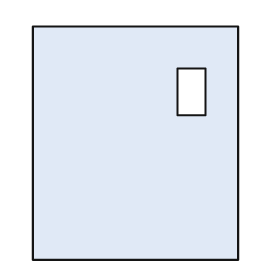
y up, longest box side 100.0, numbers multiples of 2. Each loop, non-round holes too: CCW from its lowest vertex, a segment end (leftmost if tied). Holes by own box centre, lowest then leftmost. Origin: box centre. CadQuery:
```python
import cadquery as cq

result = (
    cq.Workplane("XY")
    .moveTo(-44.0, -50.0)
    .lineTo(44.0, -50.0)
    .lineTo(44.0, 50.0)
    .lineTo(-44.0, 50.0)
    .close()
    .moveTo(18.0, 12.0)
    .lineTo(30.0, 12.0)
    .lineTo(30.0, 32.0)
    .lineTo(18.0, 32.0)
    .close()
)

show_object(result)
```